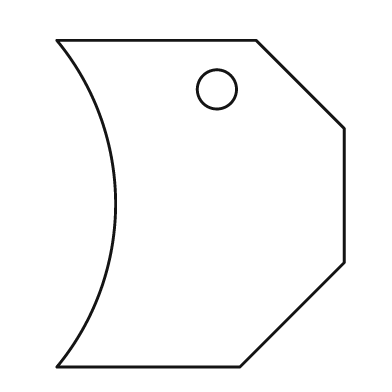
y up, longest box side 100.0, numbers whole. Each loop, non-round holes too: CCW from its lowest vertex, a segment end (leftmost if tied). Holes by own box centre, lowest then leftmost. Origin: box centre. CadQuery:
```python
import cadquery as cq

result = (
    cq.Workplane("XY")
    .moveTo(-44.0, -50.0)
    .lineTo(12.0, -50.0)
    .lineTo(44.0, -18.0)
    .lineTo(44.0, 23.0)
    .lineTo(17.0, 50.0)
    .lineTo(-44.0, 50.0)
    .threePointArc((-26.0, 0.0), (-44.0, -50.0))
    .close()
    .moveTo(5.0, 35.0)
    .circle(6.0)
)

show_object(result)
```